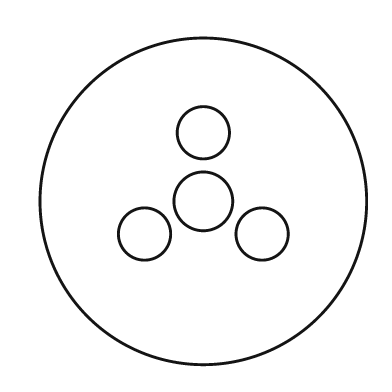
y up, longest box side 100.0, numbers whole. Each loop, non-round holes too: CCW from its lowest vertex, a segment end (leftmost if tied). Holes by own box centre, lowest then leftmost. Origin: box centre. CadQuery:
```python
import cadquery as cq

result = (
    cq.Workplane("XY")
    .moveTo(0.0, 0.0)
    .circle(50.0)
    .moveTo(-18.0, -10.0)
    .circle(8.0)
    .moveTo(18.0, -10.0)
    .circle(8.0)
    .moveTo(0.0, 0.0)
    .circle(9.0)
    .moveTo(0.0, 21.0)
    .circle(8.0)
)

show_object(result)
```